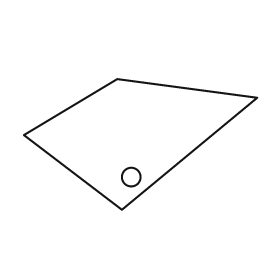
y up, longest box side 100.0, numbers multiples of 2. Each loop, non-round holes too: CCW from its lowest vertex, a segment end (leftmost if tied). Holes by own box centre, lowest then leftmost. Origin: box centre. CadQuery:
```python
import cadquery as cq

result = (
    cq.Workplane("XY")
    .moveTo(-8.0, -28.0)
    .lineTo(50.0, 20.0)
    .lineTo(-10.0, 28.0)
    .lineTo(-50.0, 4.0)
    .close()
    .moveTo(-4.0, -14.0)
    .circle(4.0)
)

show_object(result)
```